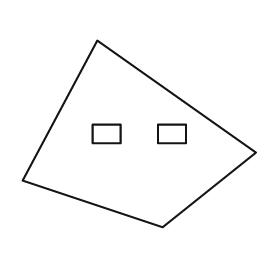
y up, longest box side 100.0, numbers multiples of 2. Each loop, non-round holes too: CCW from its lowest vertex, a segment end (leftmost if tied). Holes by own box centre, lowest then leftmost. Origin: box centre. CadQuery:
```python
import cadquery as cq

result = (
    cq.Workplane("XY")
    .moveTo(10.0, -40.0)
    .lineTo(50.0, -8.0)
    .lineTo(-18.0, 40.0)
    .lineTo(-50.0, -20.0)
    .close()
    .moveTo(-20.0, -4.0)
    .lineTo(-8.0, -4.0)
    .lineTo(-8.0, 4.0)
    .lineTo(-20.0, 4.0)
    .close()
    .moveTo(8.0, -4.0)
    .lineTo(20.0, -4.0)
    .lineTo(20.0, 4.0)
    .lineTo(8.0, 4.0)
    .close()
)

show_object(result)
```